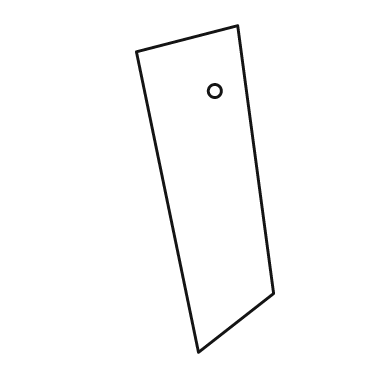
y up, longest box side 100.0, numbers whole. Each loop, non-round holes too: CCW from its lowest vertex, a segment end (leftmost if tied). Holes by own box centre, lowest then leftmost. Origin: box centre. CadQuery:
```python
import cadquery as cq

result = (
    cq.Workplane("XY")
    .moveTo(-2.0, -50.0)
    .lineTo(21.0, -32.0)
    .lineTo(10.0, 50.0)
    .lineTo(-21.0, 42.0)
    .close()
    .moveTo(3.0, 30.0)
    .circle(2.0)
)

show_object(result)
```